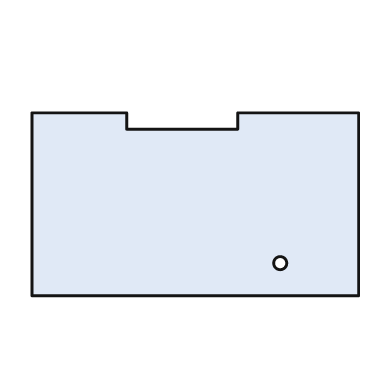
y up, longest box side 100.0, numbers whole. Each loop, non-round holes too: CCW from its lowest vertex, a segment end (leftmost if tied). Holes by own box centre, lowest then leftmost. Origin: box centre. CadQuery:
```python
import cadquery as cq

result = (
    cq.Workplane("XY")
    .moveTo(-50.0, -28.0)
    .lineTo(50.0, -28.0)
    .lineTo(50.0, 28.0)
    .lineTo(13.0, 28.0)
    .lineTo(13.0, 23.0)
    .lineTo(-21.0, 23.0)
    .lineTo(-21.0, 28.0)
    .lineTo(-50.0, 28.0)
    .close()
    .moveTo(26.0, -18.0)
    .circle(2.0)
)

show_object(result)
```